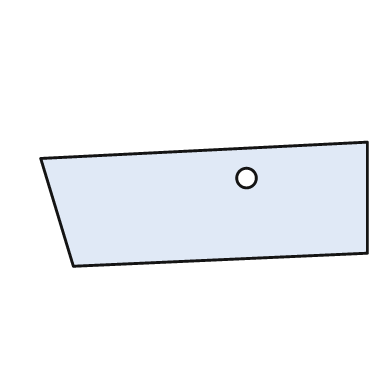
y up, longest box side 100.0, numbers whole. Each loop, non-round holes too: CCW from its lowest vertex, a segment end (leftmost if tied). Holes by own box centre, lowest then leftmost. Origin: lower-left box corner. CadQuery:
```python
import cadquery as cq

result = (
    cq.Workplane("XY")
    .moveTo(10.0, 0.0)
    .lineTo(100.0, 4.0)
    .lineTo(100.0, 38.0)
    .lineTo(0.0, 33.0)
    .close()
    .moveTo(63.0, 27.0)
    .circle(3.0)
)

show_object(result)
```